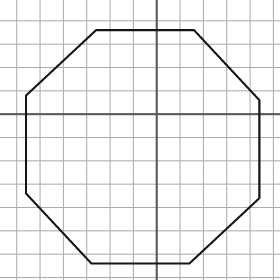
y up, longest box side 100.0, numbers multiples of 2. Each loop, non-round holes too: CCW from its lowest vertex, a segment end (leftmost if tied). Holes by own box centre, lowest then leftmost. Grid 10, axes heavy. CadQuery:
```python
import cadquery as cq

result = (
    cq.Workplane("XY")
    .moveTo(-28.0, -64.0)
    .lineTo(14.0, -64.0)
    .lineTo(44.0, -36.0)
    .lineTo(44.0, 6.0)
    .lineTo(16.0, 36.0)
    .lineTo(-26.0, 36.0)
    .lineTo(-56.0, 8.0)
    .lineTo(-56.0, -34.0)
    .close()
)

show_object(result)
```